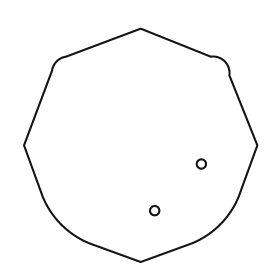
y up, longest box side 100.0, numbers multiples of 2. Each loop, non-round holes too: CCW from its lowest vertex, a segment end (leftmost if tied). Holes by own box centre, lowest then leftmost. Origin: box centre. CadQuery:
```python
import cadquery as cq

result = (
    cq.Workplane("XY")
    .moveTo(0.0, -50.0)
    .lineTo(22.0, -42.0)
    .threePointArc((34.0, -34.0), (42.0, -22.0))
    .lineTo(50.0, 0.0)
    .lineTo(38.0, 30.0)
    .threePointArc((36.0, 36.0), (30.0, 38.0))
    .lineTo(0.0, 50.0)
    .lineTo(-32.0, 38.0)
    .threePointArc((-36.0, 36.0), (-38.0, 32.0))
    .lineTo(-50.0, 0.0)
    .lineTo(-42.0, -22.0)
    .threePointArc((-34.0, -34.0), (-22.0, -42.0))
    .close()
    .moveTo(6.0, -28.0)
    .circle(2.0)
    .moveTo(26.0, -8.0)
    .circle(2.0)
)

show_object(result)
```